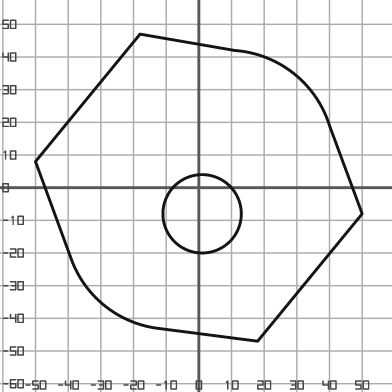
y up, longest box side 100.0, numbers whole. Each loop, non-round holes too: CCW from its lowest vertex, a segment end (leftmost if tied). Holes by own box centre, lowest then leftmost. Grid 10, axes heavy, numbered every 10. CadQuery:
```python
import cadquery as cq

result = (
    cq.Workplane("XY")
    .moveTo(18.0, -47.0)
    .lineTo(50.0, -8.0)
    .lineTo(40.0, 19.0)
    .threePointArc((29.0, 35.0), (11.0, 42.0))
    .lineTo(-18.0, 47.0)
    .lineTo(-50.0, 8.0)
    .lineTo(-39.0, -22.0)
    .threePointArc((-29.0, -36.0), (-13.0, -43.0))
    .close()
    .moveTo(1.0, -8.0)
    .circle(12.0)
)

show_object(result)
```